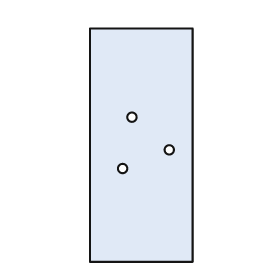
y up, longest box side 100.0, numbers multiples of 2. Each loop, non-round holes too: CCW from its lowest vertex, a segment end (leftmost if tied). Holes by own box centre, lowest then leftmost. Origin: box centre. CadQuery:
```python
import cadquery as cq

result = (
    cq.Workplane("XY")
    .moveTo(-22.0, -50.0)
    .lineTo(22.0, -50.0)
    .lineTo(22.0, 50.0)
    .lineTo(-22.0, 50.0)
    .close()
    .moveTo(-8.0, -10.0)
    .circle(2.0)
    .moveTo(12.0, -2.0)
    .circle(2.0)
    .moveTo(-4.0, 12.0)
    .circle(2.0)
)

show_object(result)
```